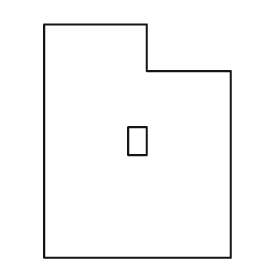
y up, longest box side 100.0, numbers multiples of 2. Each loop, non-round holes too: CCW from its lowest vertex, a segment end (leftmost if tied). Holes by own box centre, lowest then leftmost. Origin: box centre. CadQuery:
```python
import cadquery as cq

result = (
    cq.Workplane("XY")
    .moveTo(-40.0, -50.0)
    .lineTo(40.0, -50.0)
    .lineTo(40.0, 30.0)
    .lineTo(4.0, 30.0)
    .lineTo(4.0, 50.0)
    .lineTo(-40.0, 50.0)
    .close()
    .moveTo(-4.0, -6.0)
    .lineTo(4.0, -6.0)
    .lineTo(4.0, 6.0)
    .lineTo(-4.0, 6.0)
    .close()
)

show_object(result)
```